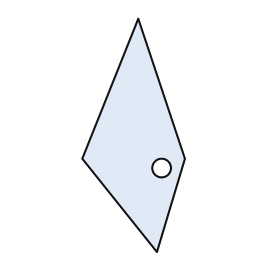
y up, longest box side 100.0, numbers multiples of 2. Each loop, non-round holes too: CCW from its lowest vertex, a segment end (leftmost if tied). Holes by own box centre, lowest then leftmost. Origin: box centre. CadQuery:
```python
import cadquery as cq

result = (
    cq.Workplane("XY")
    .moveTo(10.0, -50.0)
    .lineTo(22.0, -10.0)
    .lineTo(2.0, 50.0)
    .lineTo(-22.0, -10.0)
    .close()
    .moveTo(12.0, -14.0)
    .circle(4.0)
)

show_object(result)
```